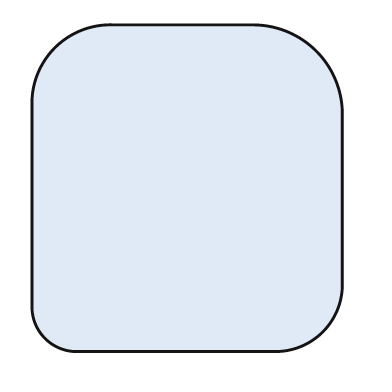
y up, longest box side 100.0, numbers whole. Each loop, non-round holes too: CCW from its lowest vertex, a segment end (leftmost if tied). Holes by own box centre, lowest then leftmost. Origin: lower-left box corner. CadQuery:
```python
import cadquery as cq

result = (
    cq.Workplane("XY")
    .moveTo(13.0, 0.0)
    .lineTo(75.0, 0.0)
    .threePointArc((89.0, 6.0), (95.0, 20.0))
    .lineTo(95.0, 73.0)
    .threePointArc((87.0, 92.0), (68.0, 100.0))
    .lineTo(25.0, 100.0)
    .threePointArc((7.0, 93.0), (0.0, 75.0))
    .lineTo(0.0, 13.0)
    .threePointArc((4.0, 4.0), (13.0, 0.0))
    .close()
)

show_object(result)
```